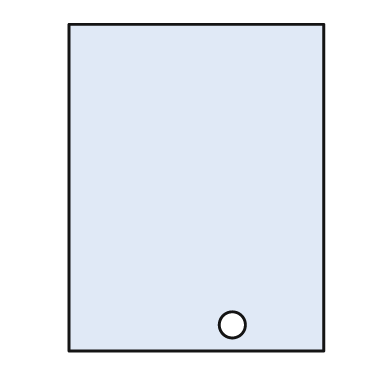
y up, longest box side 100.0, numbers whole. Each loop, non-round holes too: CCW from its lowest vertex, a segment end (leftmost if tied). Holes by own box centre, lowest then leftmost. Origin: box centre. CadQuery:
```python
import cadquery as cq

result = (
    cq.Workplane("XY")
    .moveTo(-39.0, -50.0)
    .lineTo(39.0, -50.0)
    .lineTo(39.0, 50.0)
    .lineTo(-39.0, 50.0)
    .close()
    .moveTo(11.0, -42.0)
    .circle(4.0)
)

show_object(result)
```